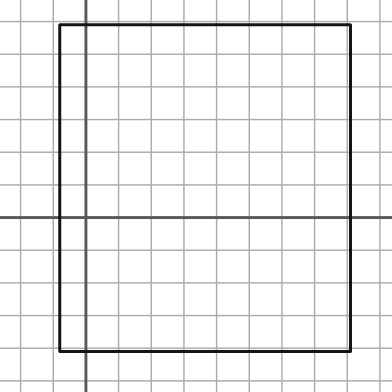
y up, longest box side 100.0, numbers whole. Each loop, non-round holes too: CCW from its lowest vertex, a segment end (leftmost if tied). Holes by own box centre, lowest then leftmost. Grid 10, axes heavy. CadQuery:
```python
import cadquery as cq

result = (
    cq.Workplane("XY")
    .moveTo(-8.0, -41.0)
    .lineTo(81.0, -41.0)
    .lineTo(81.0, 59.0)
    .lineTo(-8.0, 59.0)
    .close()
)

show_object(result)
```